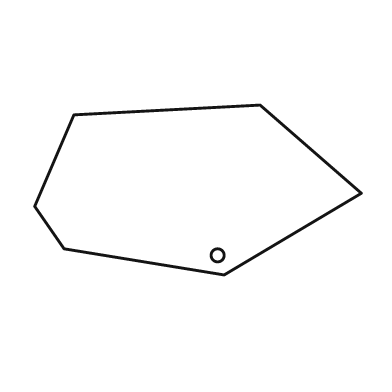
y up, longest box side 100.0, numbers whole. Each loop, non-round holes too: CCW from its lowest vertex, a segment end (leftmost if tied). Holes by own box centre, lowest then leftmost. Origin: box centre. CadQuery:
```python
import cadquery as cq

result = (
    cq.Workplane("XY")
    .moveTo(8.0, -26.0)
    .lineTo(50.0, -1.0)
    .lineTo(19.0, 26.0)
    .lineTo(-38.0, 23.0)
    .lineTo(-50.0, -5.0)
    .lineTo(-41.0, -18.0)
    .close()
    .moveTo(6.0, -20.0)
    .circle(2.0)
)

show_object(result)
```